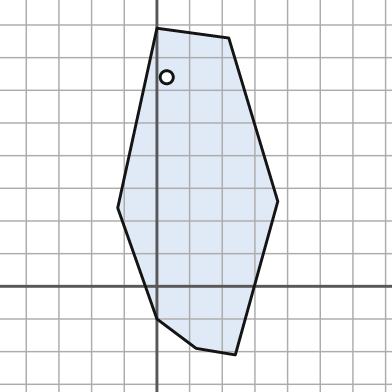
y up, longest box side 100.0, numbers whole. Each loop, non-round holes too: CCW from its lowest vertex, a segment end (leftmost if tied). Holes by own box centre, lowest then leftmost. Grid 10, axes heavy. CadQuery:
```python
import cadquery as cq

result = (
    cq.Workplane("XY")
    .moveTo(24.0, -21.0)
    .lineTo(37.0, 26.0)
    .lineTo(22.0, 76.0)
    .lineTo(0.0, 79.0)
    .lineTo(-12.0, 24.0)
    .lineTo(0.0, -10.0)
    .lineTo(12.0, -19.0)
    .close()
    .moveTo(3.0, 64.0)
    .circle(2.0)
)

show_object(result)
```